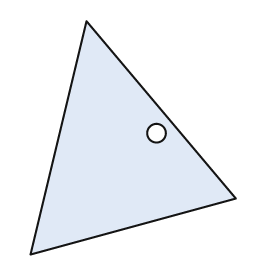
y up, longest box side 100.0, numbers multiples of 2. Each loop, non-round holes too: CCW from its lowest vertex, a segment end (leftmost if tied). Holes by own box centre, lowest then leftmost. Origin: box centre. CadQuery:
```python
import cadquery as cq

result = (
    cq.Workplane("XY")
    .moveTo(-44.0, -50.0)
    .lineTo(44.0, -26.0)
    .lineTo(-20.0, 50.0)
    .close()
    .moveTo(10.0, 2.0)
    .circle(4.0)
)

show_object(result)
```